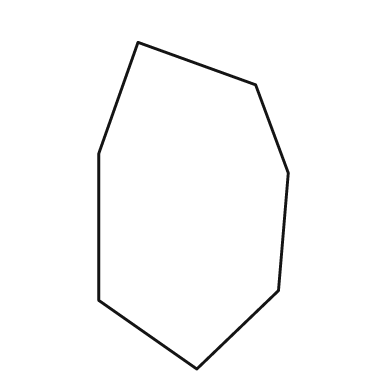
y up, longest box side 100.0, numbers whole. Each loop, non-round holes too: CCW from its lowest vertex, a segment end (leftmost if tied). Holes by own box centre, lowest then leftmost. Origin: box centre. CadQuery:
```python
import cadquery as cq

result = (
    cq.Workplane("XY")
    .moveTo(1.0, -50.0)
    .lineTo(26.0, -26.0)
    .lineTo(29.0, 10.0)
    .lineTo(19.0, 37.0)
    .lineTo(-17.0, 50.0)
    .lineTo(-29.0, 16.0)
    .lineTo(-29.0, -29.0)
    .close()
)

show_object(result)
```